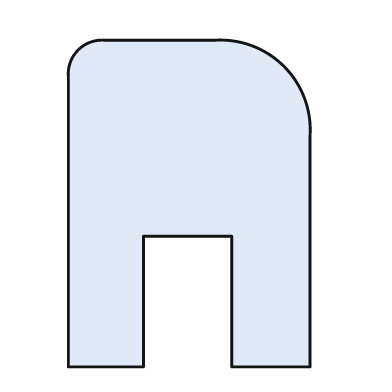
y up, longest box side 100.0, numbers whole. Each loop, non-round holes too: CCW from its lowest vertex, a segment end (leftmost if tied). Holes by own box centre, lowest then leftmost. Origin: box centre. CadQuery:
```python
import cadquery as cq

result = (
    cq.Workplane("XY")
    .moveTo(-37.0, -50.0)
    .lineTo(-14.0, -50.0)
    .lineTo(-14.0, -10.0)
    .lineTo(13.0, -10.0)
    .lineTo(13.0, -50.0)
    .lineTo(37.0, -50.0)
    .lineTo(37.0, 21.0)
    .threePointArc((29.0, 42.0), (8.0, 50.0))
    .lineTo(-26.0, 50.0)
    .threePointArc((-34.0, 47.0), (-37.0, 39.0))
    .close()
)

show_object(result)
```